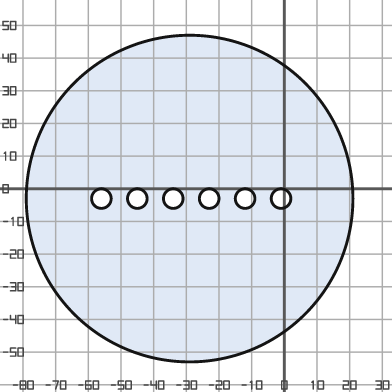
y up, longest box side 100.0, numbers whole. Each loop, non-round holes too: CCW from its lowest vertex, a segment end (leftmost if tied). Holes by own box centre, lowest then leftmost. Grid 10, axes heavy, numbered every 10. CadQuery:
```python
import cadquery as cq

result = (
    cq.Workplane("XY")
    .moveTo(-29.0, -3.0)
    .circle(50.0)
    .moveTo(-56.0, -3.0)
    .circle(3.0)
    .moveTo(-45.0, -3.0)
    .circle(3.0)
    .moveTo(-34.0, -3.0)
    .circle(3.0)
    .moveTo(-23.0, -3.0)
    .circle(3.0)
    .moveTo(-12.0, -3.0)
    .circle(3.0)
    .moveTo(-1.0, -3.0)
    .circle(3.0)
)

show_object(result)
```